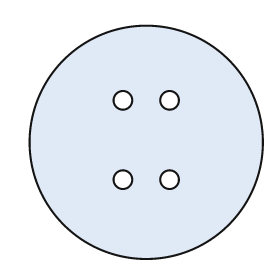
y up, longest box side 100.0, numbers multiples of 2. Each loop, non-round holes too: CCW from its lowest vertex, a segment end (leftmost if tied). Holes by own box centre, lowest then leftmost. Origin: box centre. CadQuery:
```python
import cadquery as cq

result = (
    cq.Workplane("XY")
    .moveTo(0.0, 0.0)
    .circle(50.0)
    .moveTo(-10.0, -16.0)
    .circle(4.0)
    .moveTo(10.0, -16.0)
    .circle(4.0)
    .moveTo(-10.0, 18.0)
    .circle(4.0)
    .moveTo(10.0, 18.0)
    .circle(4.0)
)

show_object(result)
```